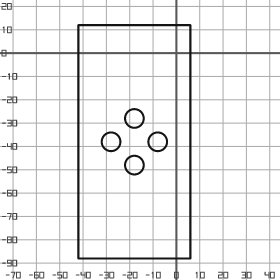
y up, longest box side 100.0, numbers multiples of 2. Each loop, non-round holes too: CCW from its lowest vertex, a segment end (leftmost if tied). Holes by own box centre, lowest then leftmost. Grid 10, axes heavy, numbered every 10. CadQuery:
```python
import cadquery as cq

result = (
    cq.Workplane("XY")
    .moveTo(-42.0, -88.0)
    .lineTo(6.0, -88.0)
    .lineTo(6.0, 12.0)
    .lineTo(-42.0, 12.0)
    .close()
    .moveTo(-18.0, -48.0)
    .circle(4.0)
    .moveTo(-28.0, -38.0)
    .circle(4.0)
    .moveTo(-8.0, -38.0)
    .circle(4.0)
    .moveTo(-18.0, -28.0)
    .circle(4.0)
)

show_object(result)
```